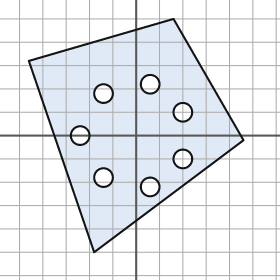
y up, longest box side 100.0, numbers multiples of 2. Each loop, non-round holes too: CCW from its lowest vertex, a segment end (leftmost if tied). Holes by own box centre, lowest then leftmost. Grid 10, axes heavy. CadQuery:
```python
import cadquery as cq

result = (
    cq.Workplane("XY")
    .moveTo(-18.0, -50.0)
    .lineTo(46.0, -2.0)
    .lineTo(16.0, 50.0)
    .lineTo(-46.0, 32.0)
    .close()
    .moveTo(6.0, -22.0)
    .circle(4.0)
    .moveTo(-14.0, -18.0)
    .circle(4.0)
    .moveTo(20.0, -10.0)
    .circle(4.0)
    .moveTo(-24.0, 0.0)
    .circle(4.0)
    .moveTo(20.0, 10.0)
    .circle(4.0)
    .moveTo(-14.0, 18.0)
    .circle(4.0)
    .moveTo(6.0, 22.0)
    .circle(4.0)
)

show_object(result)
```